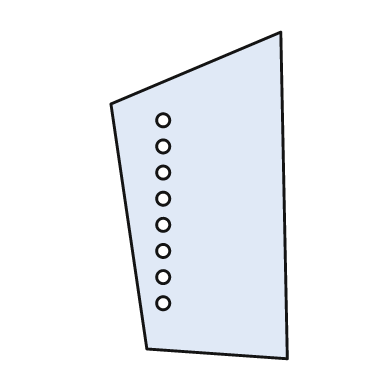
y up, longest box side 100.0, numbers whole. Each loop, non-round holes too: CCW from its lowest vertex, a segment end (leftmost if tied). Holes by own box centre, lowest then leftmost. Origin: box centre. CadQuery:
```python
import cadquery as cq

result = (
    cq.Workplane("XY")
    .moveTo(27.0, -50.0)
    .lineTo(25.0, 50.0)
    .lineTo(-27.0, 28.0)
    .lineTo(-16.0, -47.0)
    .close()
    .moveTo(-11.0, -33.0)
    .circle(2.0)
    .moveTo(-11.0, -25.0)
    .circle(2.0)
    .moveTo(-11.0, -17.0)
    .circle(2.0)
    .moveTo(-11.0, -9.0)
    .circle(2.0)
    .moveTo(-11.0, -1.0)
    .circle(2.0)
    .moveTo(-11.0, 7.0)
    .circle(2.0)
    .moveTo(-11.0, 15.0)
    .circle(2.0)
    .moveTo(-11.0, 23.0)
    .circle(2.0)
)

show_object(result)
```